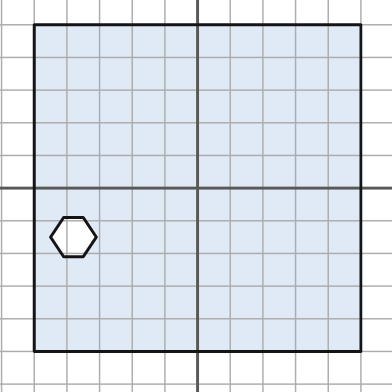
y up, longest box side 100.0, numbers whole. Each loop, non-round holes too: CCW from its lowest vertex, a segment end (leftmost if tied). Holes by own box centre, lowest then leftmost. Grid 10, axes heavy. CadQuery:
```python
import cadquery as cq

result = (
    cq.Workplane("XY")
    .moveTo(-50.0, -50.0)
    .lineTo(50.0, -50.0)
    .lineTo(50.0, 50.0)
    .lineTo(-50.0, 50.0)
    .close()
    .moveTo(-41.0, -21.0)
    .lineTo(-35.0, -21.0)
    .lineTo(-31.0, -15.0)
    .lineTo(-35.0, -9.0)
    .lineTo(-41.0, -9.0)
    .lineTo(-45.0, -15.0)
    .close()
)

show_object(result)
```